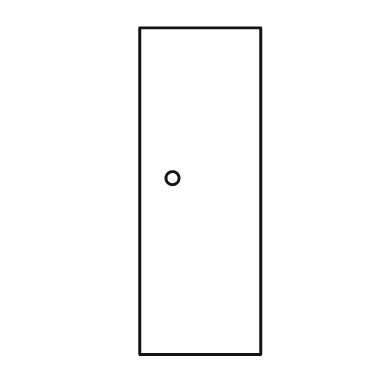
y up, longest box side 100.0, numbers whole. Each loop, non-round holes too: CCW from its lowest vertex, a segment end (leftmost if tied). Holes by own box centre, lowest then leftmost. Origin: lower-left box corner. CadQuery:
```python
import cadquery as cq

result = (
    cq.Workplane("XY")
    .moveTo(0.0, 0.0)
    .lineTo(37.0, 0.0)
    .lineTo(37.0, 100.0)
    .lineTo(0.0, 100.0)
    .close()
    .moveTo(10.0, 54.0)
    .circle(2.0)
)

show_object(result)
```